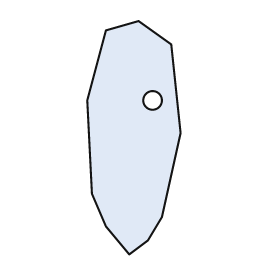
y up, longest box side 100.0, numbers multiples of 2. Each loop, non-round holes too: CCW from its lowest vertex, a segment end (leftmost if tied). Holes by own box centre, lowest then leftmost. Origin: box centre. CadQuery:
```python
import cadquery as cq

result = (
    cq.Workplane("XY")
    .moveTo(-2.0, -50.0)
    .lineTo(6.0, -44.0)
    .lineTo(12.0, -34.0)
    .lineTo(20.0, 2.0)
    .lineTo(16.0, 40.0)
    .lineTo(2.0, 50.0)
    .lineTo(-12.0, 46.0)
    .lineTo(-20.0, 16.0)
    .lineTo(-18.0, -24.0)
    .lineTo(-12.0, -38.0)
    .close()
    .moveTo(8.0, 16.0)
    .circle(4.0)
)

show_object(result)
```